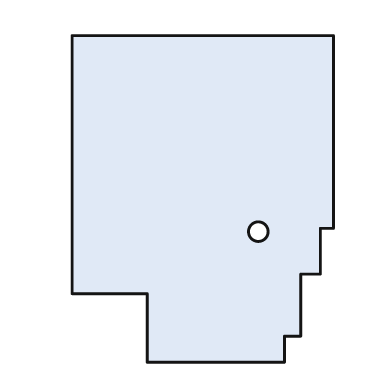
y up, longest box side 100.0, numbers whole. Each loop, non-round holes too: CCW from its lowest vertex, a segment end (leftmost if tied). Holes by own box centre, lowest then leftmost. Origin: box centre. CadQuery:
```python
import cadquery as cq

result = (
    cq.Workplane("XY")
    .moveTo(-17.0, -50.0)
    .lineTo(25.0, -50.0)
    .lineTo(25.0, -42.0)
    .lineTo(30.0, -42.0)
    .lineTo(30.0, -23.0)
    .lineTo(36.0, -23.0)
    .lineTo(36.0, -9.0)
    .lineTo(40.0, -9.0)
    .lineTo(40.0, 50.0)
    .lineTo(-40.0, 50.0)
    .lineTo(-40.0, -29.0)
    .lineTo(-17.0, -29.0)
    .close()
    .moveTo(17.0, -10.0)
    .circle(3.0)
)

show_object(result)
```